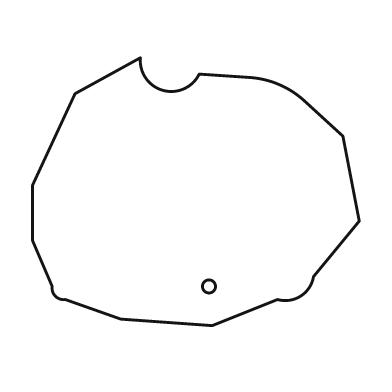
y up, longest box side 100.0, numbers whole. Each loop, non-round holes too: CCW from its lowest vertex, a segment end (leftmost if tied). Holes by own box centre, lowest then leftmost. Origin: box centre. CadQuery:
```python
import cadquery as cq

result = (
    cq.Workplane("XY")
    .moveTo(5.0, -41.0)
    .lineTo(25.0, -33.0)
    .threePointArc((32.0, -32.0), (36.0, -26.0))
    .lineTo(50.0, -9.0)
    .lineTo(45.0, 17.0)
    .lineTo(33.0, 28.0)
    .threePointArc((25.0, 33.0), (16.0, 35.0))
    .lineTo(1.0, 36.0)
    .threePointArc((-10.0, 31.0), (-17.0, 41.0))
    .lineTo(-37.0, 30.0)
    .lineTo(-50.0, 2.0)
    .lineTo(-50.0, -15.0)
    .lineTo(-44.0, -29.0)
    .threePointArc((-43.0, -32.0), (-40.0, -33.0))
    .lineTo(-23.0, -39.0)
    .close()
    .moveTo(4.0, -29.0)
    .circle(2.0)
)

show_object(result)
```